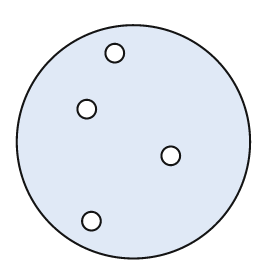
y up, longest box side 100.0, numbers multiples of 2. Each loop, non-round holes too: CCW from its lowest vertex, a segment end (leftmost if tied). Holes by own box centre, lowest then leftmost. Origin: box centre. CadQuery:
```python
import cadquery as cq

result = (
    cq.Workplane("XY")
    .moveTo(0.0, 0.0)
    .circle(50.0)
    .moveTo(-18.0, -34.0)
    .circle(4.0)
    .moveTo(16.0, -6.0)
    .circle(4.0)
    .moveTo(-20.0, 14.0)
    .circle(4.0)
    .moveTo(-8.0, 38.0)
    .circle(4.0)
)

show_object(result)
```